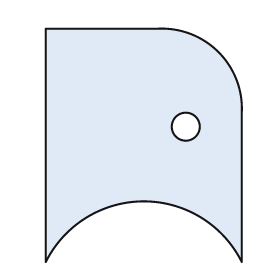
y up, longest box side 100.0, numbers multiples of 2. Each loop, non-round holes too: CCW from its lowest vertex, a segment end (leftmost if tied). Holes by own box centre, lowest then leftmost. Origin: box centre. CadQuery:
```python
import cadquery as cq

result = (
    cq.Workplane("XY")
    .moveTo(-42.0, -50.0)
    .threePointArc((0.0, -24.0), (42.0, -50.0))
    .lineTo(42.0, 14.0)
    .threePointArc((32.0, 40.0), (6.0, 50.0))
    .lineTo(-42.0, 50.0)
    .close()
    .moveTo(18.0, 8.0)
    .circle(6.0)
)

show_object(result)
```